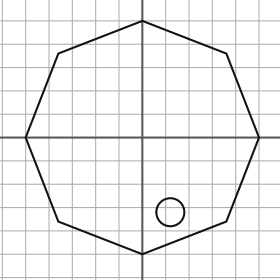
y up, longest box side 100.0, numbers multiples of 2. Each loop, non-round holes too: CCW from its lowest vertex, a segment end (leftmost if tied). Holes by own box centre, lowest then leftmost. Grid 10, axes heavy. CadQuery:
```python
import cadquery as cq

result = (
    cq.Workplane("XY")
    .moveTo(0.0, -50.0)
    .lineTo(36.0, -36.0)
    .lineTo(50.0, 0.0)
    .lineTo(36.0, 36.0)
    .lineTo(0.0, 50.0)
    .lineTo(-36.0, 36.0)
    .lineTo(-50.0, 0.0)
    .lineTo(-36.0, -36.0)
    .close()
    .moveTo(12.0, -32.0)
    .circle(6.0)
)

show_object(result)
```